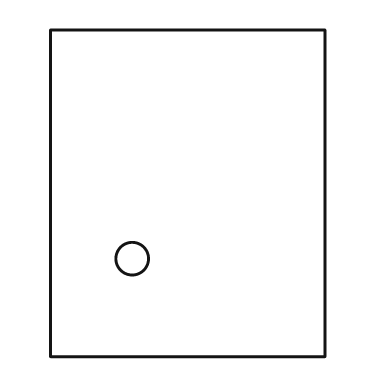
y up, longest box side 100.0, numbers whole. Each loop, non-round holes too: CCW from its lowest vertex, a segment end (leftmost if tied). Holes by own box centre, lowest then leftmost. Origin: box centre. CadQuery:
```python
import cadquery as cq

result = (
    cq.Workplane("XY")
    .moveTo(-42.0, -50.0)
    .lineTo(42.0, -50.0)
    .lineTo(42.0, 50.0)
    .lineTo(-42.0, 50.0)
    .close()
    .moveTo(-17.0, -20.0)
    .circle(5.0)
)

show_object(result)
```